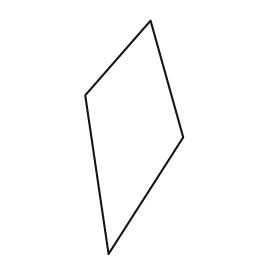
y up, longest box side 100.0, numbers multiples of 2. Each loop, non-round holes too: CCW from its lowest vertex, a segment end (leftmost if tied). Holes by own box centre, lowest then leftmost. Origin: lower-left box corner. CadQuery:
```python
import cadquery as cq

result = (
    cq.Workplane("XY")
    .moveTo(10.0, 0.0)
    .lineTo(42.0, 50.0)
    .lineTo(28.0, 100.0)
    .lineTo(0.0, 68.0)
    .close()
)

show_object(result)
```